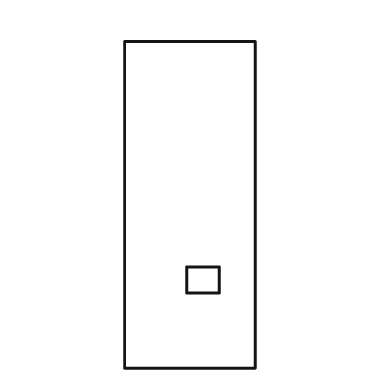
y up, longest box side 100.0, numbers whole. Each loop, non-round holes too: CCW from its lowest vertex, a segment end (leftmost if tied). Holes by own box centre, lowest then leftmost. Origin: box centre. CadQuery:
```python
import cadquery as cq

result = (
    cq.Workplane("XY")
    .moveTo(-20.0, -50.0)
    .lineTo(20.0, -50.0)
    .lineTo(20.0, 50.0)
    .lineTo(-20.0, 50.0)
    .close()
    .moveTo(-1.0, -27.0)
    .lineTo(9.0, -27.0)
    .lineTo(9.0, -19.0)
    .lineTo(-1.0, -19.0)
    .close()
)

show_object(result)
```